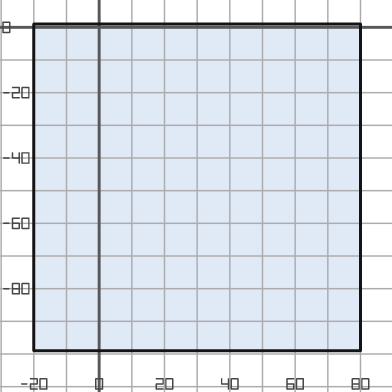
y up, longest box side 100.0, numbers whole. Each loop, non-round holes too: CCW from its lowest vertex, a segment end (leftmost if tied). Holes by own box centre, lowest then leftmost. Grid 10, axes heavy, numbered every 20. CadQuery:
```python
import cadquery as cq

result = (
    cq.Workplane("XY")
    .moveTo(-20.0, -99.0)
    .lineTo(80.0, -99.0)
    .lineTo(80.0, 1.0)
    .lineTo(-20.0, 1.0)
    .close()
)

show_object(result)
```